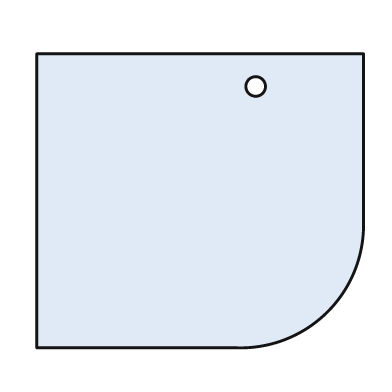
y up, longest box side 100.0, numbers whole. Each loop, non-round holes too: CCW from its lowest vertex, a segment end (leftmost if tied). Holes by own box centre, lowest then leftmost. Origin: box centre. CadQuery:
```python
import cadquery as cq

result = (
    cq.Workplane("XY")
    .moveTo(-50.0, -45.0)
    .lineTo(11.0, -45.0)
    .threePointArc((39.0, -34.0), (50.0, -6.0))
    .lineTo(50.0, 45.0)
    .lineTo(-50.0, 45.0)
    .close()
    .moveTo(17.0, 35.0)
    .circle(3.0)
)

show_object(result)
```